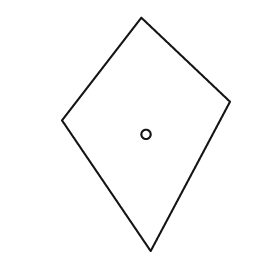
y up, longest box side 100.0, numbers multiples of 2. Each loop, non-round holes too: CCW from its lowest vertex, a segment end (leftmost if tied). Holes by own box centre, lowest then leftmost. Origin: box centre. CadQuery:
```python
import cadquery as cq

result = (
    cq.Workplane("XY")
    .moveTo(2.0, -50.0)
    .lineTo(36.0, 14.0)
    .lineTo(-2.0, 50.0)
    .lineTo(-36.0, 6.0)
    .close()
    .moveTo(0.0, 0.0)
    .circle(2.0)
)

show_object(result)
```